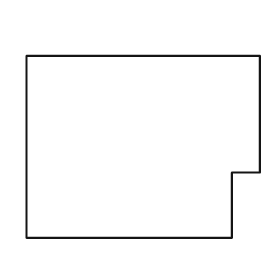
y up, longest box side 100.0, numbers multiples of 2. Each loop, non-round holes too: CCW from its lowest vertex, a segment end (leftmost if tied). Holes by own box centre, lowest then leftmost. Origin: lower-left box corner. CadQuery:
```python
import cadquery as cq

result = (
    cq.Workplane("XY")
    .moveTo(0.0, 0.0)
    .lineTo(88.0, 0.0)
    .lineTo(88.0, 28.0)
    .lineTo(100.0, 28.0)
    .lineTo(100.0, 78.0)
    .lineTo(0.0, 78.0)
    .close()
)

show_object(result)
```